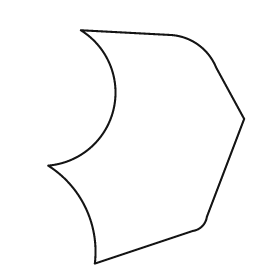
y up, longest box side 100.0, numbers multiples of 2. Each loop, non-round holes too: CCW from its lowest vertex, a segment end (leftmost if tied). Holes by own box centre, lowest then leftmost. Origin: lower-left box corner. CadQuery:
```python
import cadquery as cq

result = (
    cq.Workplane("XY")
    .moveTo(20.0, 0.0)
    .lineTo(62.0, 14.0)
    .threePointArc((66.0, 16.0), (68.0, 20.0))
    .lineTo(84.0, 62.0)
    .lineTo(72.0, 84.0)
    .threePointArc((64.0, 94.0), (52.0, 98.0))
    .lineTo(14.0, 100.0)
    .threePointArc((28.0, 66.0), (0.0, 42.0))
    .threePointArc((16.0, 24.0), (20.0, 0.0))
    .close()
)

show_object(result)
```